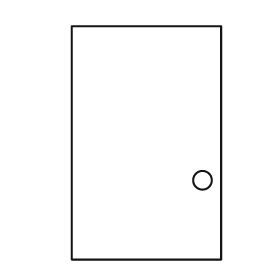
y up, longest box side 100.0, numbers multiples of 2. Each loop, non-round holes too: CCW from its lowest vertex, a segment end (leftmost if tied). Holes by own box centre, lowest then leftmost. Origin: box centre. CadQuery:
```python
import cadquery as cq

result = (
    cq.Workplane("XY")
    .moveTo(-32.0, -50.0)
    .lineTo(32.0, -50.0)
    .lineTo(32.0, 50.0)
    .lineTo(-32.0, 50.0)
    .close()
    .moveTo(24.0, -16.0)
    .circle(4.0)
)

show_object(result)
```